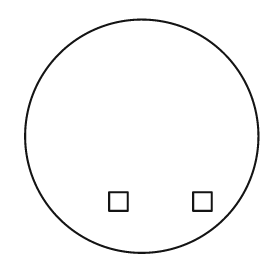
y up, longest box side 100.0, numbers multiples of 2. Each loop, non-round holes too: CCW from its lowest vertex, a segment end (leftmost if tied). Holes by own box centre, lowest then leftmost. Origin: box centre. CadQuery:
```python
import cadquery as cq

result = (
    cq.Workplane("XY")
    .moveTo(0.0, 0.0)
    .circle(50.0)
    .moveTo(-14.0, -32.0)
    .lineTo(-6.0, -32.0)
    .lineTo(-6.0, -24.0)
    .lineTo(-14.0, -24.0)
    .close()
    .moveTo(22.0, -32.0)
    .lineTo(30.0, -32.0)
    .lineTo(30.0, -24.0)
    .lineTo(22.0, -24.0)
    .close()
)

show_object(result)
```